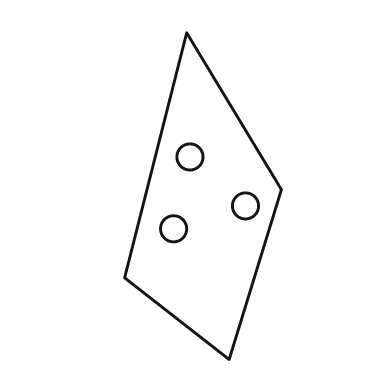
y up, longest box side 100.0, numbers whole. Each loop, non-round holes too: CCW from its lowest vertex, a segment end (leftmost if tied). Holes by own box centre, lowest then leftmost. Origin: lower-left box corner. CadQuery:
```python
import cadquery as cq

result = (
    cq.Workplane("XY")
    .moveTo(32.0, 0.0)
    .lineTo(48.0, 52.0)
    .lineTo(19.0, 100.0)
    .lineTo(0.0, 25.0)
    .close()
    .moveTo(15.0, 40.0)
    .circle(4.0)
    .moveTo(37.0, 47.0)
    .circle(4.0)
    .moveTo(20.0, 62.0)
    .circle(4.0)
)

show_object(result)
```